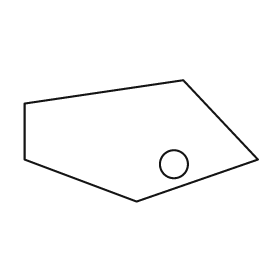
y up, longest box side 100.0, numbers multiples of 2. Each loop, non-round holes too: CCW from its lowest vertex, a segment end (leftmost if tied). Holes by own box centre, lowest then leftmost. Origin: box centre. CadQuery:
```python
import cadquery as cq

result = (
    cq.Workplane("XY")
    .moveTo(-2.0, -26.0)
    .lineTo(50.0, -8.0)
    .lineTo(18.0, 26.0)
    .lineTo(-50.0, 16.0)
    .lineTo(-50.0, -8.0)
    .close()
    .moveTo(14.0, -10.0)
    .circle(6.0)
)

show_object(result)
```